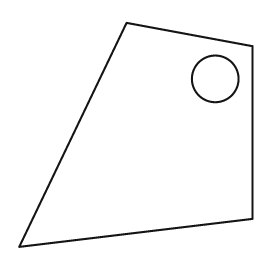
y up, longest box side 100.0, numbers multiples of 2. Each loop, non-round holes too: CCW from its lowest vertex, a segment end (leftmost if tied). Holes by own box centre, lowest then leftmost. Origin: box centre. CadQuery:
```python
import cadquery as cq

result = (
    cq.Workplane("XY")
    .moveTo(-50.0, -48.0)
    .lineTo(50.0, -36.0)
    .lineTo(50.0, 38.0)
    .lineTo(-4.0, 48.0)
    .close()
    .moveTo(34.0, 24.0)
    .circle(10.0)
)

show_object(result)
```